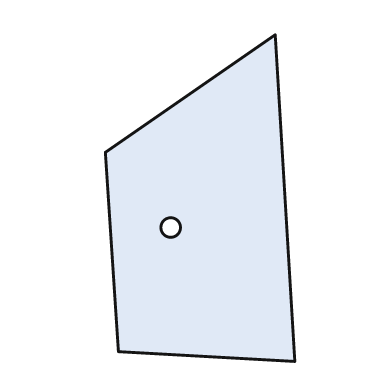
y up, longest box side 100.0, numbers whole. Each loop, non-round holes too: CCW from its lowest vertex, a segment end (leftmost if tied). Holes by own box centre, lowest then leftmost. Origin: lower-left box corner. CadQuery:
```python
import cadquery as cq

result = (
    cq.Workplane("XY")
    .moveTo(58.0, 0.0)
    .lineTo(52.0, 100.0)
    .lineTo(0.0, 64.0)
    .lineTo(4.0, 3.0)
    .close()
    .moveTo(20.0, 41.0)
    .circle(3.0)
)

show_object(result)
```